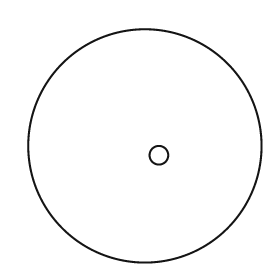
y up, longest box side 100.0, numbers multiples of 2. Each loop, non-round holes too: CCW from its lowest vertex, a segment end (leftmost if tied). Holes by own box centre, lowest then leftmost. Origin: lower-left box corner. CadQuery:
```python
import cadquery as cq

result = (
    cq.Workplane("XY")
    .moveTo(50.0, 50.0)
    .circle(50.0)
    .moveTo(56.0, 46.0)
    .circle(4.0)
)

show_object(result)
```